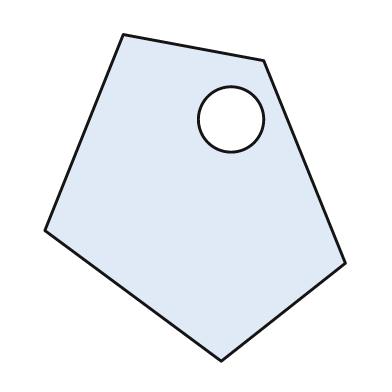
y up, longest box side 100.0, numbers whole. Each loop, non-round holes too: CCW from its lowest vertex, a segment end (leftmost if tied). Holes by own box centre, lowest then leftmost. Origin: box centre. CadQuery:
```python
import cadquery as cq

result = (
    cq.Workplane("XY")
    .moveTo(8.0, -50.0)
    .lineTo(46.0, -20.0)
    .lineTo(21.0, 42.0)
    .lineTo(-22.0, 50.0)
    .lineTo(-46.0, -10.0)
    .close()
    .moveTo(11.0, 24.0)
    .circle(10.0)
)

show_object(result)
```